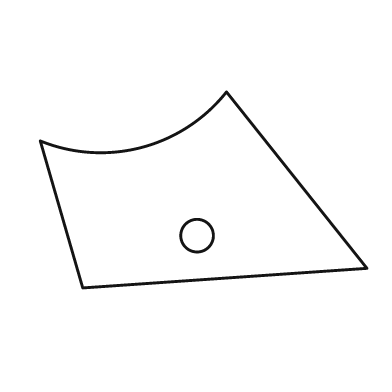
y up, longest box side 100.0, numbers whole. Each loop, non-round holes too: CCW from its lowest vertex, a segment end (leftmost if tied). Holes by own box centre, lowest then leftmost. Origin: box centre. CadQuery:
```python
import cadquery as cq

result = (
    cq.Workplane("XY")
    .moveTo(-37.0, -30.0)
    .lineTo(50.0, -24.0)
    .lineTo(7.0, 30.0)
    .threePointArc((-19.0, 13.0), (-50.0, 15.0))
    .close()
    .moveTo(-2.0, -14.0)
    .circle(5.0)
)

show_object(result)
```